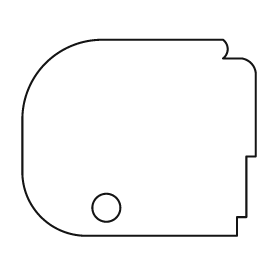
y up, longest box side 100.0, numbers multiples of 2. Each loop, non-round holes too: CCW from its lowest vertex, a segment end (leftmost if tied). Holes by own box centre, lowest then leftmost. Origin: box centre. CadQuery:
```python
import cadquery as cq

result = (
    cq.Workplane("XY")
    .moveTo(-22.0, -42.0)
    .lineTo(42.0, -42.0)
    .lineTo(42.0, -34.0)
    .lineTo(46.0, -34.0)
    .lineTo(46.0, -8.0)
    .lineTo(50.0, -8.0)
    .lineTo(50.0, 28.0)
    .threePointArc((48.0, 32.0), (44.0, 34.0))
    .lineTo(36.0, 34.0)
    .threePointArc((38.0, 38.0), (36.0, 42.0))
    .lineTo(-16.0, 42.0)
    .threePointArc((-40.0, 32.0), (-50.0, 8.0))
    .lineTo(-50.0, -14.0)
    .threePointArc((-42.0, -34.0), (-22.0, -42.0))
    .close()
    .moveTo(-14.0, -30.0)
    .circle(6.0)
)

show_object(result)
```